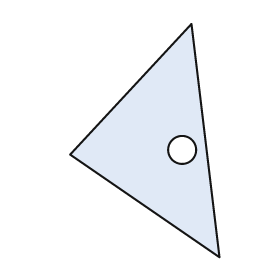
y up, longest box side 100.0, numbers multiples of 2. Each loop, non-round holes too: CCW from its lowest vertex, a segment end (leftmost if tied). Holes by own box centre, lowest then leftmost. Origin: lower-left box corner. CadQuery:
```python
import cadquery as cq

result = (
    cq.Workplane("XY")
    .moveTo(64.0, 0.0)
    .lineTo(52.0, 100.0)
    .lineTo(0.0, 44.0)
    .close()
    .moveTo(48.0, 46.0)
    .circle(6.0)
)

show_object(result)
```